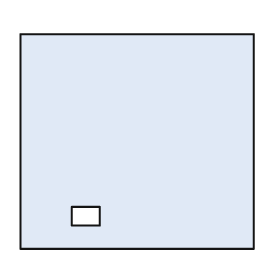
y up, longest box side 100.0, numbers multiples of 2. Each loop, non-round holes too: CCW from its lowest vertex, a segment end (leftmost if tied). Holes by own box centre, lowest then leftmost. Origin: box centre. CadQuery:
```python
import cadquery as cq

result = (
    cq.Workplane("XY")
    .moveTo(-50.0, -46.0)
    .lineTo(50.0, -46.0)
    .lineTo(50.0, 46.0)
    .lineTo(-50.0, 46.0)
    .close()
    .moveTo(-28.0, -36.0)
    .lineTo(-16.0, -36.0)
    .lineTo(-16.0, -28.0)
    .lineTo(-28.0, -28.0)
    .close()
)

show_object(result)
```